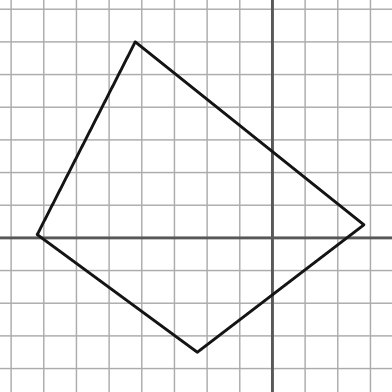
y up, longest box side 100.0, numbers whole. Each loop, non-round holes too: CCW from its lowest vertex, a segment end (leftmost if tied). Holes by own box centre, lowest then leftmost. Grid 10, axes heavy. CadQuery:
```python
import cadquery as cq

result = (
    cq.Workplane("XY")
    .moveTo(-23.0, -35.0)
    .lineTo(28.0, 4.0)
    .lineTo(-42.0, 60.0)
    .lineTo(-72.0, 1.0)
    .close()
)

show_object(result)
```